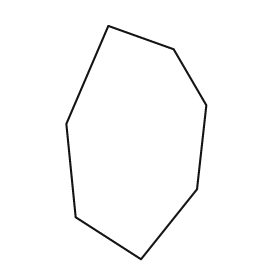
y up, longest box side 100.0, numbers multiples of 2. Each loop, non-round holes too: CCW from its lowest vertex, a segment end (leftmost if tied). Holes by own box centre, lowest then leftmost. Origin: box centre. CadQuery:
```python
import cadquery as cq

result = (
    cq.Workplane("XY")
    .moveTo(2.0, -50.0)
    .lineTo(26.0, -20.0)
    .lineTo(30.0, 16.0)
    .lineTo(16.0, 40.0)
    .lineTo(-12.0, 50.0)
    .lineTo(-30.0, 8.0)
    .lineTo(-26.0, -32.0)
    .close()
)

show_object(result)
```